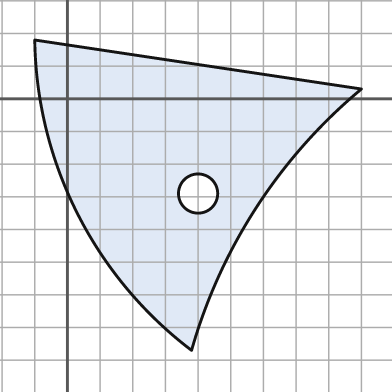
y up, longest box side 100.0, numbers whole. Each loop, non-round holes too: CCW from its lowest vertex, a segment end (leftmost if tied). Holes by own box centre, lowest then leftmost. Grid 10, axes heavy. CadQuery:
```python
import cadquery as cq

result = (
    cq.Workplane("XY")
    .moveTo(38.0, -77.0)
    .threePointArc((58.0, -33.0), (90.0, 3.0))
    .lineTo(-10.0, 18.0)
    .threePointArc((3.0, -35.0), (38.0, -77.0))
    .close()
    .moveTo(40.0, -29.0)
    .circle(6.0)
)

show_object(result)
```